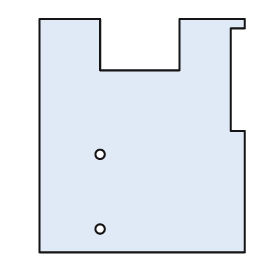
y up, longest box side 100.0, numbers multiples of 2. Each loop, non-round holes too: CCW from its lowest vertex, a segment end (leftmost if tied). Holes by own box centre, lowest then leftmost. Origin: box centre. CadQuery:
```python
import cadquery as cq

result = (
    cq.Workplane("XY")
    .moveTo(-44.0, -50.0)
    .lineTo(44.0, -50.0)
    .lineTo(44.0, 2.0)
    .lineTo(38.0, 2.0)
    .lineTo(38.0, 46.0)
    .lineTo(44.0, 46.0)
    .lineTo(44.0, 50.0)
    .lineTo(16.0, 50.0)
    .lineTo(16.0, 28.0)
    .lineTo(-18.0, 28.0)
    .lineTo(-18.0, 50.0)
    .lineTo(-44.0, 50.0)
    .close()
    .moveTo(-18.0, -40.0)
    .circle(2.0)
    .moveTo(-18.0, -8.0)
    .circle(2.0)
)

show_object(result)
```